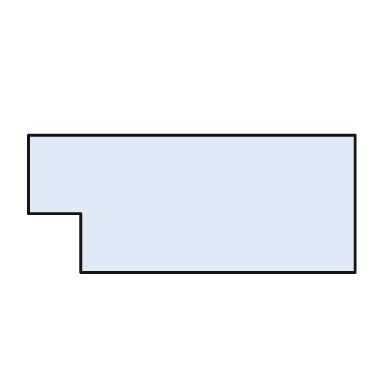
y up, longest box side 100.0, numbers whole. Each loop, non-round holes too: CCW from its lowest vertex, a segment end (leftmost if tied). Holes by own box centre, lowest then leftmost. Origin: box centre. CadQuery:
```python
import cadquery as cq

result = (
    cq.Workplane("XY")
    .moveTo(-34.0, -21.0)
    .lineTo(50.0, -21.0)
    .lineTo(50.0, 21.0)
    .lineTo(-50.0, 21.0)
    .lineTo(-50.0, -3.0)
    .lineTo(-34.0, -3.0)
    .close()
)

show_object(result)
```